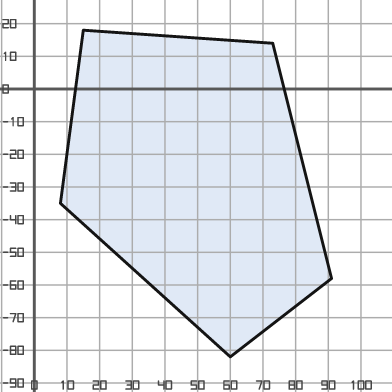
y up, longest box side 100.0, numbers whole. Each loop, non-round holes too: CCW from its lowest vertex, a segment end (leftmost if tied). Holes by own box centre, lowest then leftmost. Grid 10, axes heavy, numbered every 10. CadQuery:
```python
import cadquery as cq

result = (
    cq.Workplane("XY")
    .moveTo(60.0, -82.0)
    .lineTo(91.0, -58.0)
    .lineTo(73.0, 14.0)
    .lineTo(15.0, 18.0)
    .lineTo(8.0, -35.0)
    .close()
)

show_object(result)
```